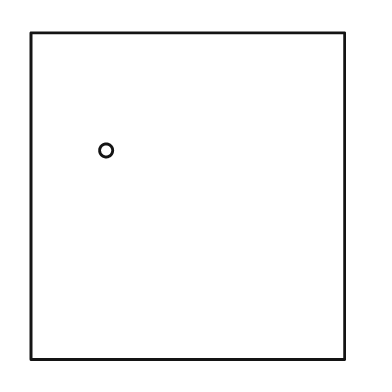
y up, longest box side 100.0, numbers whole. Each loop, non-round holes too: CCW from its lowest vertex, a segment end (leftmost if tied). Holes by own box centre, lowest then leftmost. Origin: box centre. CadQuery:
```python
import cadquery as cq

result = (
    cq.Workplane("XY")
    .moveTo(-48.0, -50.0)
    .lineTo(48.0, -50.0)
    .lineTo(48.0, 50.0)
    .lineTo(-48.0, 50.0)
    .close()
    .moveTo(-25.0, 14.0)
    .circle(2.0)
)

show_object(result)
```